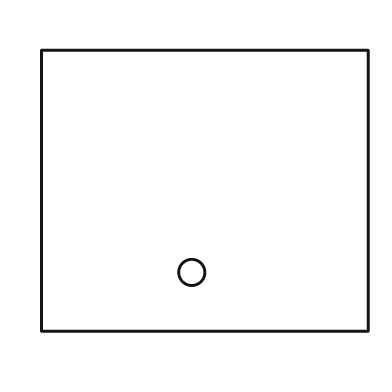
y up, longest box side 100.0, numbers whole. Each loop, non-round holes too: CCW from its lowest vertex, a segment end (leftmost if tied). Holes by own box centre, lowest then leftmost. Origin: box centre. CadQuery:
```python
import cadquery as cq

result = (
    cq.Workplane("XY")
    .moveTo(-50.0, -43.0)
    .lineTo(50.0, -43.0)
    .lineTo(50.0, 43.0)
    .lineTo(-50.0, 43.0)
    .close()
    .moveTo(-4.0, -25.0)
    .circle(4.0)
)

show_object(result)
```